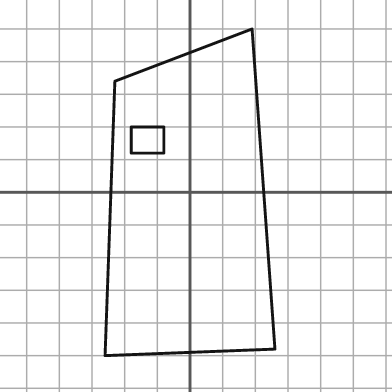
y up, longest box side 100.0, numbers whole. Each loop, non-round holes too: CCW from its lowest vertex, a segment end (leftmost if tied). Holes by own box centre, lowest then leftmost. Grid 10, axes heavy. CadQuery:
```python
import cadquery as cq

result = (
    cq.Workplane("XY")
    .moveTo(-26.0, -50.0)
    .lineTo(26.0, -48.0)
    .lineTo(19.0, 50.0)
    .lineTo(-23.0, 34.0)
    .close()
    .moveTo(-18.0, 12.0)
    .lineTo(-8.0, 12.0)
    .lineTo(-8.0, 20.0)
    .lineTo(-18.0, 20.0)
    .close()
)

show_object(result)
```